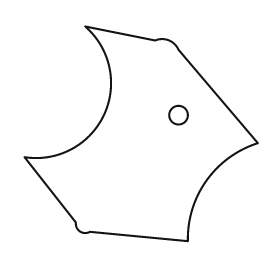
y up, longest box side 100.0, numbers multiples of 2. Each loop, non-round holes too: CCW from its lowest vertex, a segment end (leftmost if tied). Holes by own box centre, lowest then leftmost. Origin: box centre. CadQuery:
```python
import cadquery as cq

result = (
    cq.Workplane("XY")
    .moveTo(20.0, -46.0)
    .threePointArc((28.0, -20.0), (50.0, -4.0))
    .lineTo(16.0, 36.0)
    .threePointArc((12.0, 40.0), (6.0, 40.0))
    .lineTo(-24.0, 46.0)
    .threePointArc((-16.0, 8.0), (-50.0, -10.0))
    .lineTo(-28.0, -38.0)
    .threePointArc((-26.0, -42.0), (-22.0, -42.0))
    .close()
    .moveTo(16.0, 8.0)
    .circle(4.0)
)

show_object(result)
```